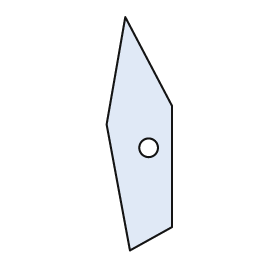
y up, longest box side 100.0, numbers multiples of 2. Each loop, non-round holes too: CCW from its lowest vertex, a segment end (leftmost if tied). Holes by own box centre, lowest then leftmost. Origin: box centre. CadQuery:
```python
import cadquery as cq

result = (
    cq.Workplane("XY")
    .moveTo(-4.0, -50.0)
    .lineTo(14.0, -40.0)
    .lineTo(14.0, 12.0)
    .lineTo(-6.0, 50.0)
    .lineTo(-14.0, 4.0)
    .close()
    .moveTo(4.0, -6.0)
    .circle(4.0)
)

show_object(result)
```